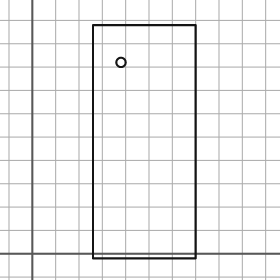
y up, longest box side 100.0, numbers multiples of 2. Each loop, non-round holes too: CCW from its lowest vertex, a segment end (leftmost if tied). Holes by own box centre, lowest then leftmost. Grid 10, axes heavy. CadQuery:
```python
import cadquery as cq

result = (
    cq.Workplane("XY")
    .moveTo(26.0, -2.0)
    .lineTo(70.0, -2.0)
    .lineTo(70.0, 98.0)
    .lineTo(26.0, 98.0)
    .close()
    .moveTo(38.0, 82.0)
    .circle(2.0)
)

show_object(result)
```